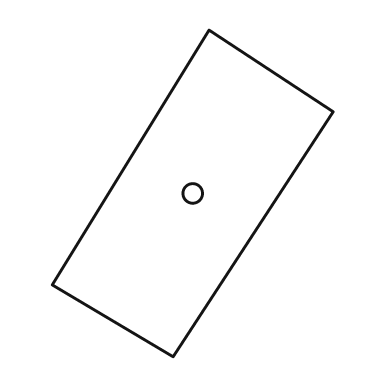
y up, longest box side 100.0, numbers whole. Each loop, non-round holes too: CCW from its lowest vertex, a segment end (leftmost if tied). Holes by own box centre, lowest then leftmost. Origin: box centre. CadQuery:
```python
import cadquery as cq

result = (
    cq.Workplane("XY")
    .moveTo(-6.0, -50.0)
    .lineTo(43.0, 25.0)
    .lineTo(5.0, 50.0)
    .lineTo(-43.0, -28.0)
    .close()
    .moveTo(0.0, 0.0)
    .circle(3.0)
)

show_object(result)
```